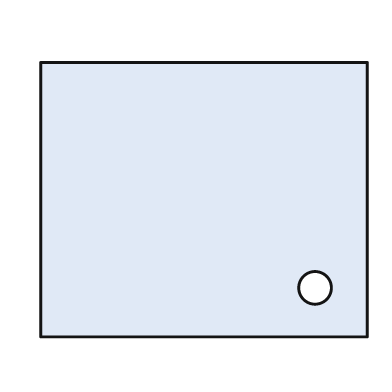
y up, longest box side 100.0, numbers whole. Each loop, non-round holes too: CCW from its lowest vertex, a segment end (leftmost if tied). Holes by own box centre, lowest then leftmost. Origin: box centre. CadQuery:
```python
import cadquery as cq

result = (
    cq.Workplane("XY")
    .moveTo(-50.0, -42.0)
    .lineTo(50.0, -42.0)
    .lineTo(50.0, 42.0)
    .lineTo(-50.0, 42.0)
    .close()
    .moveTo(34.0, -27.0)
    .circle(5.0)
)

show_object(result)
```